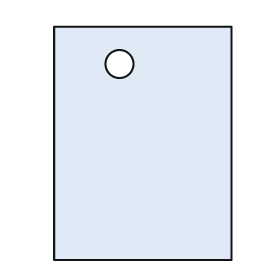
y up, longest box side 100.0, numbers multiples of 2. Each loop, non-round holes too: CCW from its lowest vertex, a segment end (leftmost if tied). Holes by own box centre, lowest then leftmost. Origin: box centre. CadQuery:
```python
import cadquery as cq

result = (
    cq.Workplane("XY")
    .moveTo(-38.0, -50.0)
    .lineTo(38.0, -50.0)
    .lineTo(38.0, 50.0)
    .lineTo(-38.0, 50.0)
    .close()
    .moveTo(-10.0, 34.0)
    .circle(6.0)
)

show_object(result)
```